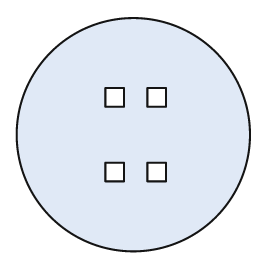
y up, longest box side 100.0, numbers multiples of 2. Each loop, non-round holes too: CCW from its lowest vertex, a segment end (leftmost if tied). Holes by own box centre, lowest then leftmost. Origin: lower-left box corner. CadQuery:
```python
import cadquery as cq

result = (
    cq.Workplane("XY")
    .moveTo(50.0, 50.0)
    .circle(50.0)
    .moveTo(38.0, 30.0)
    .lineTo(46.0, 30.0)
    .lineTo(46.0, 38.0)
    .lineTo(38.0, 38.0)
    .close()
    .moveTo(56.0, 30.0)
    .lineTo(64.0, 30.0)
    .lineTo(64.0, 38.0)
    .lineTo(56.0, 38.0)
    .close()
    .moveTo(38.0, 62.0)
    .lineTo(46.0, 62.0)
    .lineTo(46.0, 70.0)
    .lineTo(38.0, 70.0)
    .close()
    .moveTo(56.0, 62.0)
    .lineTo(64.0, 62.0)
    .lineTo(64.0, 70.0)
    .lineTo(56.0, 70.0)
    .close()
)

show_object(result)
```